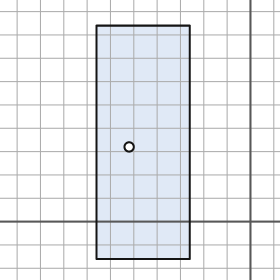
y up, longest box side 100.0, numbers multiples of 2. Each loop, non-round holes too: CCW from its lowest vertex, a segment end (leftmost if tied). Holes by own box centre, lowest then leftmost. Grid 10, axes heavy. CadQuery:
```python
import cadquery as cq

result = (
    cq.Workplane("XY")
    .moveTo(-66.0, -16.0)
    .lineTo(-26.0, -16.0)
    .lineTo(-26.0, 84.0)
    .lineTo(-66.0, 84.0)
    .close()
    .moveTo(-52.0, 32.0)
    .circle(2.0)
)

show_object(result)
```